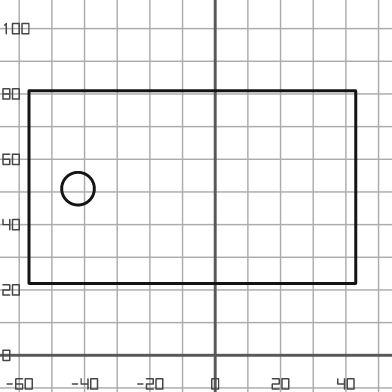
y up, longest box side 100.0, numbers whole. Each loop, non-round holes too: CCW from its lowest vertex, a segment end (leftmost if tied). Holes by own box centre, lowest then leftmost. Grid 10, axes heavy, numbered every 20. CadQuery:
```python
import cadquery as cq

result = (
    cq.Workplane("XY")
    .moveTo(-57.0, 22.0)
    .lineTo(43.0, 22.0)
    .lineTo(43.0, 81.0)
    .lineTo(-57.0, 81.0)
    .close()
    .moveTo(-42.0, 51.0)
    .circle(5.0)
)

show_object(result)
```